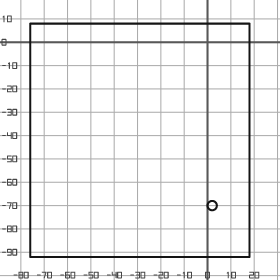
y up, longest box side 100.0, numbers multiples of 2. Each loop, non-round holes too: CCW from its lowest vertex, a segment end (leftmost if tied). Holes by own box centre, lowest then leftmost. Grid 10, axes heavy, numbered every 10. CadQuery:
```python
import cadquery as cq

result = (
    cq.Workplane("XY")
    .moveTo(-76.0, -92.0)
    .lineTo(18.0, -92.0)
    .lineTo(18.0, 8.0)
    .lineTo(-76.0, 8.0)
    .close()
    .moveTo(2.0, -70.0)
    .circle(2.0)
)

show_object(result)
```